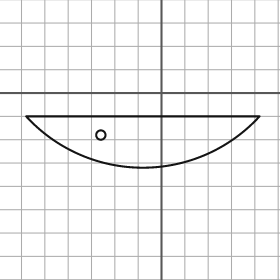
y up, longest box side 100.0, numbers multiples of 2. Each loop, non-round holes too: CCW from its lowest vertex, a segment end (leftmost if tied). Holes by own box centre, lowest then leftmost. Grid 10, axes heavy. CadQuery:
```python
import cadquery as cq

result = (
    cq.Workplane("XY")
    .moveTo(-58.0, -10.0)
    .threePointArc((-8.0, -32.0), (42.0, -10.0))
    .close()
    .moveTo(-26.0, -18.0)
    .circle(2.0)
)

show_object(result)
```